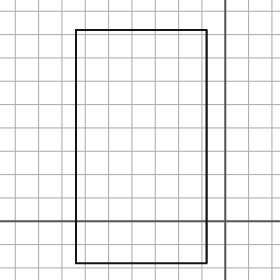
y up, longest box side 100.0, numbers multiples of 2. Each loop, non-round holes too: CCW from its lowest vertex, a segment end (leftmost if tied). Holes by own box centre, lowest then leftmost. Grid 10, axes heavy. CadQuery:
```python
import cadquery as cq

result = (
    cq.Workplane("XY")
    .moveTo(-64.0, -18.0)
    .lineTo(-8.0, -18.0)
    .lineTo(-8.0, 82.0)
    .lineTo(-64.0, 82.0)
    .close()
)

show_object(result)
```